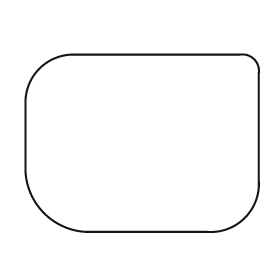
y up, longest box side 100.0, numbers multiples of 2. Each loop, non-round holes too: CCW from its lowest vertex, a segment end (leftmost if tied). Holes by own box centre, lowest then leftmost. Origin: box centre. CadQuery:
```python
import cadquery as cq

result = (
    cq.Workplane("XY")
    .moveTo(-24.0, -38.0)
    .lineTo(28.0, -38.0)
    .threePointArc((44.0, -32.0), (50.0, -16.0))
    .lineTo(50.0, 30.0)
    .threePointArc((48.0, 36.0), (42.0, 38.0))
    .lineTo(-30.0, 38.0)
    .threePointArc((-44.0, 32.0), (-50.0, 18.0))
    .lineTo(-50.0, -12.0)
    .threePointArc((-42.0, -30.0), (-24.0, -38.0))
    .close()
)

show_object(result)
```